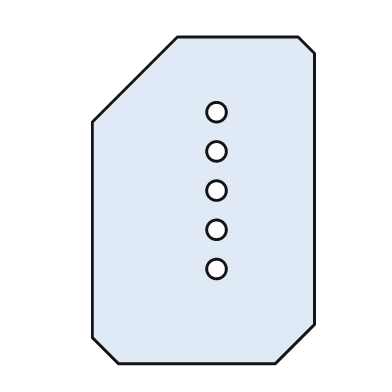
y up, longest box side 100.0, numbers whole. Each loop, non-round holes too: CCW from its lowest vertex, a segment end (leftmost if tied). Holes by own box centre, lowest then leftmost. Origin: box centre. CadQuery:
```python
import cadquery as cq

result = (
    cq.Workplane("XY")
    .moveTo(-26.0, -50.0)
    .lineTo(22.0, -50.0)
    .lineTo(34.0, -38.0)
    .lineTo(34.0, 45.0)
    .lineTo(29.0, 50.0)
    .lineTo(-8.0, 50.0)
    .lineTo(-34.0, 24.0)
    .lineTo(-34.0, -42.0)
    .close()
    .moveTo(4.0, -21.0)
    .circle(3.0)
    .moveTo(4.0, -9.0)
    .circle(3.0)
    .moveTo(4.0, 3.0)
    .circle(3.0)
    .moveTo(4.0, 15.0)
    .circle(3.0)
    .moveTo(4.0, 27.0)
    .circle(3.0)
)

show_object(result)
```